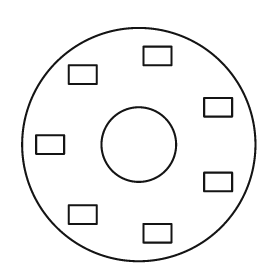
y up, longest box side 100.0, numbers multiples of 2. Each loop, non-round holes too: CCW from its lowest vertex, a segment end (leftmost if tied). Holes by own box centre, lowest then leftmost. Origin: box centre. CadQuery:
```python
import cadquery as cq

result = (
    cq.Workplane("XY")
    .moveTo(0.0, 0.0)
    .circle(50.0)
    .moveTo(2.0, -42.0)
    .lineTo(14.0, -42.0)
    .lineTo(14.0, -34.0)
    .lineTo(2.0, -34.0)
    .close()
    .moveTo(-30.0, -34.0)
    .lineTo(-18.0, -34.0)
    .lineTo(-18.0, -26.0)
    .lineTo(-30.0, -26.0)
    .close()
    .moveTo(28.0, -20.0)
    .lineTo(40.0, -20.0)
    .lineTo(40.0, -12.0)
    .lineTo(28.0, -12.0)
    .close()
    .moveTo(-44.0, -4.0)
    .lineTo(-32.0, -4.0)
    .lineTo(-32.0, 4.0)
    .lineTo(-44.0, 4.0)
    .close()
    .moveTo(0.0, 0.0)
    .circle(16.0)
    .moveTo(28.0, 12.0)
    .lineTo(40.0, 12.0)
    .lineTo(40.0, 20.0)
    .lineTo(28.0, 20.0)
    .close()
    .moveTo(-30.0, 26.0)
    .lineTo(-18.0, 26.0)
    .lineTo(-18.0, 34.0)
    .lineTo(-30.0, 34.0)
    .close()
    .moveTo(2.0, 34.0)
    .lineTo(14.0, 34.0)
    .lineTo(14.0, 42.0)
    .lineTo(2.0, 42.0)
    .close()
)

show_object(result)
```